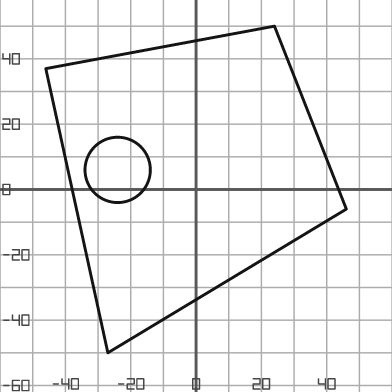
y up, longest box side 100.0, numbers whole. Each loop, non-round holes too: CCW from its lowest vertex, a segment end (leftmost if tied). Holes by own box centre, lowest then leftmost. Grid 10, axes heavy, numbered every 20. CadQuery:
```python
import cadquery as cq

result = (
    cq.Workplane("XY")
    .moveTo(-27.0, -50.0)
    .lineTo(46.0, -6.0)
    .lineTo(24.0, 50.0)
    .lineTo(-46.0, 37.0)
    .close()
    .moveTo(-24.0, 6.0)
    .circle(10.0)
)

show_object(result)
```